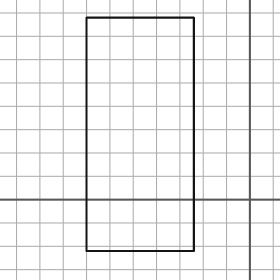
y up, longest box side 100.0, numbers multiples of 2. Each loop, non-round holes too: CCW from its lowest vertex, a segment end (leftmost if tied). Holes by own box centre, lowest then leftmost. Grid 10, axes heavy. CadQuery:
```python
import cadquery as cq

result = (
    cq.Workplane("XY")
    .moveTo(-70.0, -22.0)
    .lineTo(-24.0, -22.0)
    .lineTo(-24.0, 78.0)
    .lineTo(-70.0, 78.0)
    .close()
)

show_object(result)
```